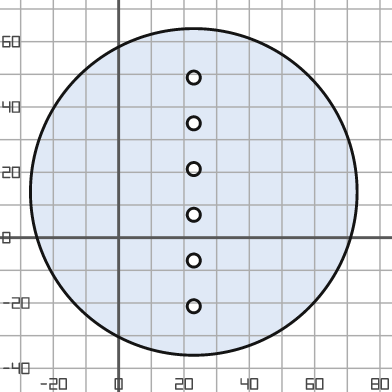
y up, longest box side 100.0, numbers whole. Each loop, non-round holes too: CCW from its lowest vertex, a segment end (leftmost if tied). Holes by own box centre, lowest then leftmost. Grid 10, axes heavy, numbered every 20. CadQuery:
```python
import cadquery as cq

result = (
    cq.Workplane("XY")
    .moveTo(23.0, 14.0)
    .circle(50.0)
    .moveTo(23.0, -21.0)
    .circle(2.0)
    .moveTo(23.0, -7.0)
    .circle(2.0)
    .moveTo(23.0, 7.0)
    .circle(2.0)
    .moveTo(23.0, 21.0)
    .circle(2.0)
    .moveTo(23.0, 35.0)
    .circle(2.0)
    .moveTo(23.0, 49.0)
    .circle(2.0)
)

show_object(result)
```